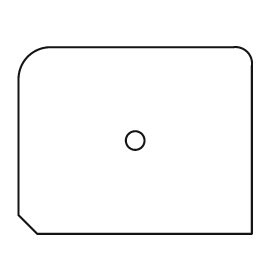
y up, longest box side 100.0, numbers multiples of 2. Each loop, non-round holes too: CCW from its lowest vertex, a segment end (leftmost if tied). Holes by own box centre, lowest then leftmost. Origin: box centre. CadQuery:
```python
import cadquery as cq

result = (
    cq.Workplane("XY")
    .moveTo(-42.0, -40.0)
    .lineTo(50.0, -40.0)
    .lineTo(50.0, 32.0)
    .threePointArc((48.0, 38.0), (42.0, 40.0))
    .lineTo(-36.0, 40.0)
    .threePointArc((-46.0, 36.0), (-50.0, 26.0))
    .lineTo(-50.0, -32.0)
    .close()
    .moveTo(0.0, 0.0)
    .circle(4.0)
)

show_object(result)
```